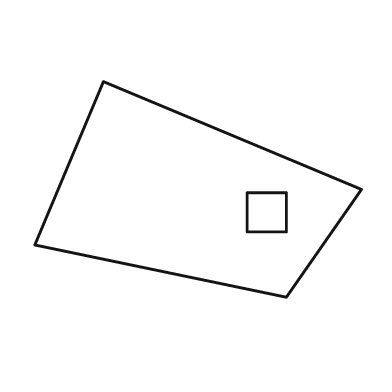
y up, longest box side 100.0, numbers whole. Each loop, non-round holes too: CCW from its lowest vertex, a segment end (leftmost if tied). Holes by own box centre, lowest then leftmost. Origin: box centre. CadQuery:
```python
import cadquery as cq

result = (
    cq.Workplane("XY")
    .moveTo(27.0, -33.0)
    .lineTo(50.0, 0.0)
    .lineTo(-29.0, 33.0)
    .lineTo(-50.0, -17.0)
    .close()
    .moveTo(15.0, -13.0)
    .lineTo(27.0, -13.0)
    .lineTo(27.0, -1.0)
    .lineTo(15.0, -1.0)
    .close()
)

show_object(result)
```